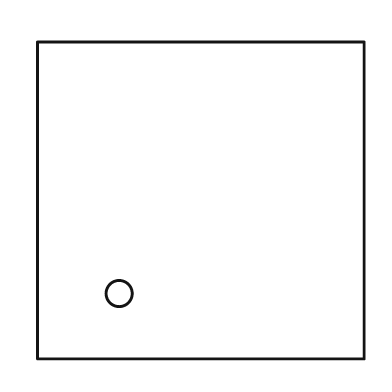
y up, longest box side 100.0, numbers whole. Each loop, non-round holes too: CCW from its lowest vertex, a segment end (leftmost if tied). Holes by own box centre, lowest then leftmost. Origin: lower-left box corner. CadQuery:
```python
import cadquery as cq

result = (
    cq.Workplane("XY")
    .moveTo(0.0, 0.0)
    .lineTo(100.0, 0.0)
    .lineTo(100.0, 97.0)
    .lineTo(0.0, 97.0)
    .close()
    .moveTo(25.0, 20.0)
    .circle(4.0)
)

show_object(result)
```